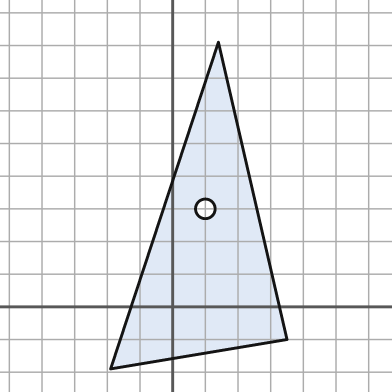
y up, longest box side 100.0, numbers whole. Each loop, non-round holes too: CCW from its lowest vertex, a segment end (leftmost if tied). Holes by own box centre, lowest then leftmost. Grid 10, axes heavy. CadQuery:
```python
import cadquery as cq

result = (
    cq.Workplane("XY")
    .moveTo(-19.0, -19.0)
    .lineTo(35.0, -10.0)
    .lineTo(14.0, 81.0)
    .close()
    .moveTo(10.0, 30.0)
    .circle(3.0)
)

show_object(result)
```